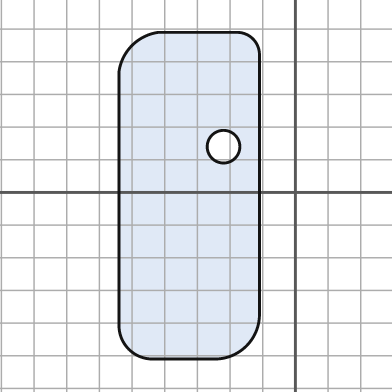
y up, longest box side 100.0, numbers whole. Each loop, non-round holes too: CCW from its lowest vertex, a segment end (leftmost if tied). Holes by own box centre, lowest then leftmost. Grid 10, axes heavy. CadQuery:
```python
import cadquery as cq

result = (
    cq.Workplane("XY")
    .moveTo(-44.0, -51.0)
    .lineTo(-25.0, -51.0)
    .threePointArc((-15.0, -47.0), (-11.0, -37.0))
    .lineTo(-11.0, 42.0)
    .threePointArc((-13.0, 47.0), (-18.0, 49.0))
    .lineTo(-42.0, 49.0)
    .threePointArc((-50.0, 45.0), (-54.0, 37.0))
    .lineTo(-54.0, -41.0)
    .threePointArc((-51.0, -48.0), (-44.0, -51.0))
    .close()
    .moveTo(-22.0, 14.0)
    .circle(5.0)
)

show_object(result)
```